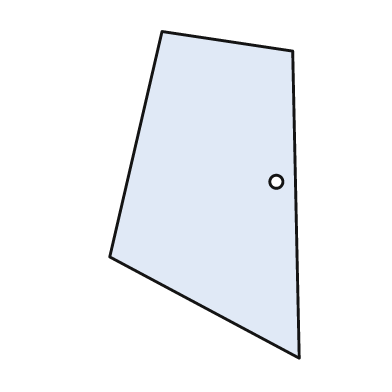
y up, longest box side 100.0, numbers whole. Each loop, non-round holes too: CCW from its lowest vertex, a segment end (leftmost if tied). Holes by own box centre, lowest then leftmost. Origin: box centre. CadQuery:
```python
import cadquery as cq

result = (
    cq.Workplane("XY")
    .moveTo(29.0, -50.0)
    .lineTo(27.0, 44.0)
    .lineTo(-13.0, 50.0)
    .lineTo(-29.0, -19.0)
    .close()
    .moveTo(22.0, 4.0)
    .circle(2.0)
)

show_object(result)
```